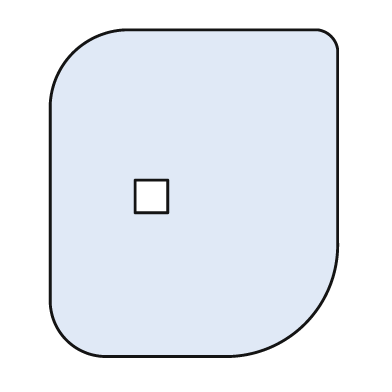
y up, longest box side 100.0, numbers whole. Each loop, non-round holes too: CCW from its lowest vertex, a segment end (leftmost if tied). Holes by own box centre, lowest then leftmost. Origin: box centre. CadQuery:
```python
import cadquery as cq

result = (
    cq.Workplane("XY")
    .moveTo(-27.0, -50.0)
    .lineTo(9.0, -50.0)
    .threePointArc((34.0, -40.0), (44.0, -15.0))
    .lineTo(44.0, 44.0)
    .threePointArc((42.0, 48.0), (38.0, 50.0))
    .lineTo(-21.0, 50.0)
    .threePointArc((-37.0, 43.0), (-44.0, 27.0))
    .lineTo(-44.0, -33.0)
    .threePointArc((-39.0, -45.0), (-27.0, -50.0))
    .close()
    .moveTo(-18.0, -6.0)
    .lineTo(-8.0, -6.0)
    .lineTo(-8.0, 4.0)
    .lineTo(-18.0, 4.0)
    .close()
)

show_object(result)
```